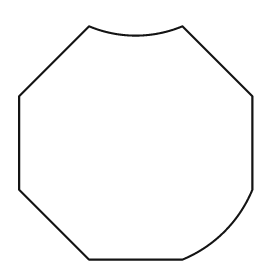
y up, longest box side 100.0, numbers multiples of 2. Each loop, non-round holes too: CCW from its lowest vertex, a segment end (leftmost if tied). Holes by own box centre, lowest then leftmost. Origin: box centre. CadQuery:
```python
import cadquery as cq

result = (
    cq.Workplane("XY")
    .moveTo(-20.0, -50.0)
    .lineTo(20.0, -50.0)
    .threePointArc((38.0, -38.0), (50.0, -20.0))
    .lineTo(50.0, 20.0)
    .lineTo(20.0, 50.0)
    .threePointArc((0.0, 46.0), (-20.0, 50.0))
    .lineTo(-50.0, 20.0)
    .lineTo(-50.0, -20.0)
    .close()
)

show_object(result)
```